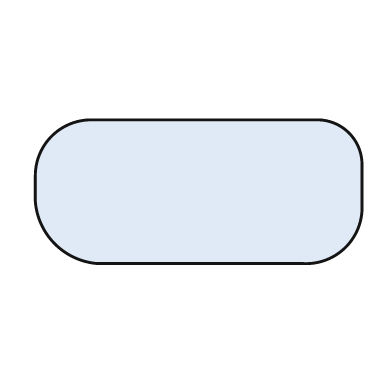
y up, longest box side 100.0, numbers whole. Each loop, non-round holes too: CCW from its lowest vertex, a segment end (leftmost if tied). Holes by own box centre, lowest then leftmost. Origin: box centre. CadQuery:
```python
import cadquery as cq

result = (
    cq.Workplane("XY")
    .moveTo(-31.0, -22.0)
    .lineTo(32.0, -22.0)
    .threePointArc((45.0, -17.0), (50.0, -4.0))
    .lineTo(50.0, 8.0)
    .threePointArc((46.0, 18.0), (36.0, 22.0))
    .lineTo(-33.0, 22.0)
    .threePointArc((-45.0, 17.0), (-50.0, 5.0))
    .lineTo(-50.0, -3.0)
    .threePointArc((-44.0, -16.0), (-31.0, -22.0))
    .close()
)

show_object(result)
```